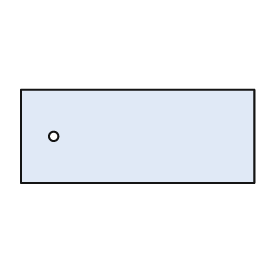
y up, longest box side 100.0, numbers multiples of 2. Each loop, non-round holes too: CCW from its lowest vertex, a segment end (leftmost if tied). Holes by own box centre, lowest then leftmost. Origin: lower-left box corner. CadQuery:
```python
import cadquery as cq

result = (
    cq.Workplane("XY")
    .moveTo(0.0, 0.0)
    .lineTo(100.0, 0.0)
    .lineTo(100.0, 40.0)
    .lineTo(0.0, 40.0)
    .close()
    .moveTo(14.0, 20.0)
    .circle(2.0)
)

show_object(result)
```